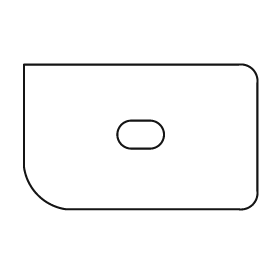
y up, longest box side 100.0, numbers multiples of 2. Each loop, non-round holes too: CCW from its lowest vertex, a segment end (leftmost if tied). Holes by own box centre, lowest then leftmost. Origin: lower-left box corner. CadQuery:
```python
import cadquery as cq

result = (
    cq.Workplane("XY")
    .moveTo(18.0, 0.0)
    .lineTo(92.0, 0.0)
    .threePointArc((98.0, 2.0), (100.0, 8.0))
    .lineTo(100.0, 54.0)
    .threePointArc((98.0, 60.0), (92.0, 62.0))
    .lineTo(0.0, 62.0)
    .lineTo(0.0, 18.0)
    .threePointArc((6.0, 6.0), (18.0, 0.0))
    .close()
    .moveTo(46.0, 26.0)
    .lineTo(54.0, 26.0)
    .threePointArc((60.0, 32.0), (54.0, 38.0))
    .lineTo(46.0, 38.0)
    .threePointArc((40.0, 32.0), (46.0, 26.0))
    .close()
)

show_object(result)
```